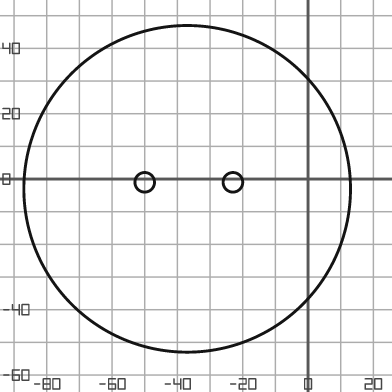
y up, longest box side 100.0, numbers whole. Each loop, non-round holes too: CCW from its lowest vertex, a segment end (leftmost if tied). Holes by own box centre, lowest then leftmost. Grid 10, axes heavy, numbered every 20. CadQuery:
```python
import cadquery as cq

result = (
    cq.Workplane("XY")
    .moveTo(-37.0, -3.0)
    .circle(50.0)
    .moveTo(-50.0, -1.0)
    .circle(3.0)
    .moveTo(-23.0, -1.0)
    .circle(3.0)
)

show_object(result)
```